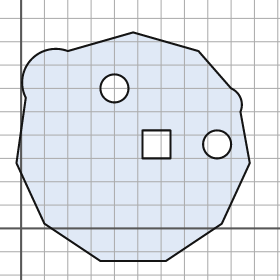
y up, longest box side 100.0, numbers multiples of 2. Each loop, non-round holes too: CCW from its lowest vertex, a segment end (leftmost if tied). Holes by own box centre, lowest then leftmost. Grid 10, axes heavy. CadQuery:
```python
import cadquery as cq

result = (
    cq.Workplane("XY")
    .moveTo(34.0, -14.0)
    .lineTo(62.0, -14.0)
    .lineTo(86.0, 2.0)
    .lineTo(98.0, 28.0)
    .lineTo(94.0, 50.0)
    .threePointArc((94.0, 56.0), (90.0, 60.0))
    .lineTo(76.0, 76.0)
    .lineTo(48.0, 84.0)
    .lineTo(20.0, 76.0)
    .threePointArc((4.0, 72.0), (2.0, 56.0))
    .lineTo(-2.0, 28.0)
    .lineTo(10.0, 2.0)
    .close()
    .moveTo(52.0, 30.0)
    .lineTo(64.0, 30.0)
    .lineTo(64.0, 42.0)
    .lineTo(52.0, 42.0)
    .close()
    .moveTo(84.0, 36.0)
    .circle(6.0)
    .moveTo(40.0, 60.0)
    .circle(6.0)
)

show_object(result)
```